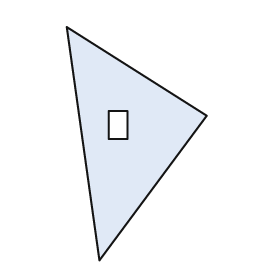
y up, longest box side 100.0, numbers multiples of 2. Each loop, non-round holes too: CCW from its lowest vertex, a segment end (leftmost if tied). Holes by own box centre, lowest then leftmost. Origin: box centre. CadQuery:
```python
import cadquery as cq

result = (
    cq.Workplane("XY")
    .moveTo(-16.0, -50.0)
    .lineTo(30.0, 12.0)
    .lineTo(-30.0, 50.0)
    .close()
    .moveTo(-12.0, 2.0)
    .lineTo(-4.0, 2.0)
    .lineTo(-4.0, 14.0)
    .lineTo(-12.0, 14.0)
    .close()
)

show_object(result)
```